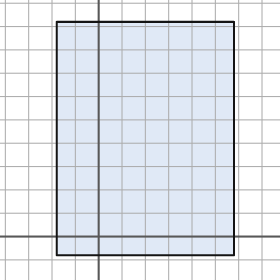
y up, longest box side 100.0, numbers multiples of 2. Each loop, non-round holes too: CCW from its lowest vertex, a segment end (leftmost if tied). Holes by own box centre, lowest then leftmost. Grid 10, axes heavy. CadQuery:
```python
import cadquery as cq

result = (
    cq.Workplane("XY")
    .moveTo(-18.0, -8.0)
    .lineTo(58.0, -8.0)
    .lineTo(58.0, 92.0)
    .lineTo(-18.0, 92.0)
    .close()
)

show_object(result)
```